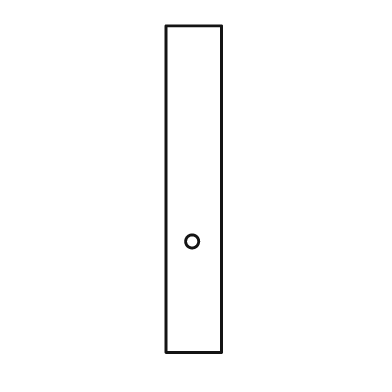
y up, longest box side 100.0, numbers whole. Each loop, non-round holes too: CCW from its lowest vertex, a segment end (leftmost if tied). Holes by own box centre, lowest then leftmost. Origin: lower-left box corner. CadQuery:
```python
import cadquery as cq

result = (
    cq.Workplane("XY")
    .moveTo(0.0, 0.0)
    .lineTo(17.0, 0.0)
    .lineTo(17.0, 100.0)
    .lineTo(0.0, 100.0)
    .close()
    .moveTo(8.0, 34.0)
    .circle(2.0)
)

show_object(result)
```